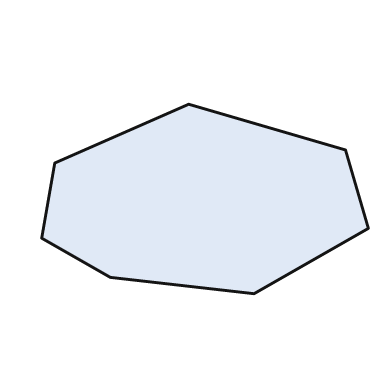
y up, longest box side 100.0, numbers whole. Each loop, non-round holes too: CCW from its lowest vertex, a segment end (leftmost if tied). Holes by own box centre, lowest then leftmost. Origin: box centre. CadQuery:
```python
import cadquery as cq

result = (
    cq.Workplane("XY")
    .moveTo(15.0, -29.0)
    .lineTo(50.0, -9.0)
    .lineTo(43.0, 15.0)
    .lineTo(-5.0, 29.0)
    .lineTo(-46.0, 11.0)
    .lineTo(-50.0, -12.0)
    .lineTo(-29.0, -24.0)
    .close()
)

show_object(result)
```